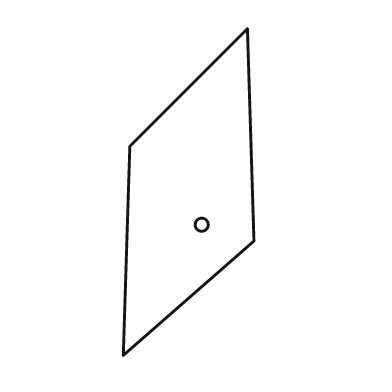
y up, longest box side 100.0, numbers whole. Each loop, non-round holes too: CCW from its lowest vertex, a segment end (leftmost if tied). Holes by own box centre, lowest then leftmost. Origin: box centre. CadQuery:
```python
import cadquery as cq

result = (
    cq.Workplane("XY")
    .moveTo(-20.0, -50.0)
    .lineTo(20.0, -15.0)
    .lineTo(18.0, 50.0)
    .lineTo(-18.0, 14.0)
    .close()
    .moveTo(4.0, -10.0)
    .circle(2.0)
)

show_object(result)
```